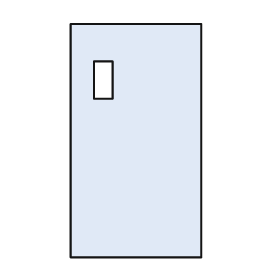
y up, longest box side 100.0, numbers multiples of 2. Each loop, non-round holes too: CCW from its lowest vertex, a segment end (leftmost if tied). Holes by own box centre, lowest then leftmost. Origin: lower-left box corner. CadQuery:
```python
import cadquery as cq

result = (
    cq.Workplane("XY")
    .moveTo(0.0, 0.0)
    .lineTo(56.0, 0.0)
    .lineTo(56.0, 100.0)
    .lineTo(0.0, 100.0)
    .close()
    .moveTo(10.0, 68.0)
    .lineTo(18.0, 68.0)
    .lineTo(18.0, 84.0)
    .lineTo(10.0, 84.0)
    .close()
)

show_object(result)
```